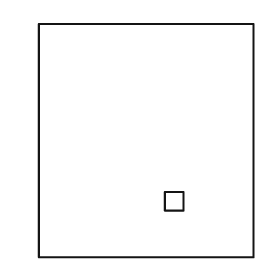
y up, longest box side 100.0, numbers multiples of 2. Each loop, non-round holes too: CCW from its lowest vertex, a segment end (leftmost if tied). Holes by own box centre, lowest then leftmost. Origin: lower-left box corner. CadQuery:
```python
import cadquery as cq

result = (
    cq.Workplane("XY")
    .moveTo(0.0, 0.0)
    .lineTo(92.0, 0.0)
    .lineTo(92.0, 100.0)
    .lineTo(0.0, 100.0)
    .close()
    .moveTo(54.0, 20.0)
    .lineTo(62.0, 20.0)
    .lineTo(62.0, 28.0)
    .lineTo(54.0, 28.0)
    .close()
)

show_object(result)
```